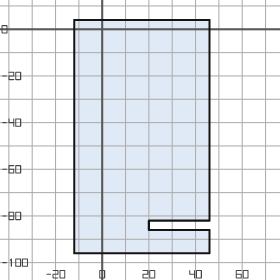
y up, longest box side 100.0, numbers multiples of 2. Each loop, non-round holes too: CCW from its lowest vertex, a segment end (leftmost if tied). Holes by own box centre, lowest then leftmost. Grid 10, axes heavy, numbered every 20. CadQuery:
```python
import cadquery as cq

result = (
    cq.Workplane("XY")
    .moveTo(-12.0, -96.0)
    .lineTo(46.0, -96.0)
    .lineTo(46.0, -86.0)
    .lineTo(20.0, -86.0)
    .lineTo(20.0, -82.0)
    .lineTo(46.0, -82.0)
    .lineTo(46.0, 4.0)
    .lineTo(-12.0, 4.0)
    .close()
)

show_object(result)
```